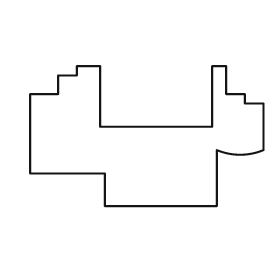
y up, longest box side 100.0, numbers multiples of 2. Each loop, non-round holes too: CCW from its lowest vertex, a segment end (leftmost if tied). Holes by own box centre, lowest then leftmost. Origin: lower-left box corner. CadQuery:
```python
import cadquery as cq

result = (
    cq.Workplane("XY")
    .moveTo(32.0, 0.0)
    .lineTo(80.0, 0.0)
    .lineTo(80.0, 24.0)
    .threePointArc((90.0, 22.0), (100.0, 24.0))
    .lineTo(100.0, 44.0)
    .lineTo(92.0, 44.0)
    .lineTo(92.0, 48.0)
    .lineTo(84.0, 48.0)
    .lineTo(84.0, 60.0)
    .lineTo(78.0, 60.0)
    .lineTo(78.0, 34.0)
    .lineTo(30.0, 34.0)
    .lineTo(30.0, 60.0)
    .lineTo(20.0, 60.0)
    .lineTo(20.0, 56.0)
    .lineTo(12.0, 56.0)
    .lineTo(12.0, 48.0)
    .lineTo(0.0, 48.0)
    .lineTo(0.0, 14.0)
    .lineTo(32.0, 14.0)
    .close()
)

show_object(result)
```